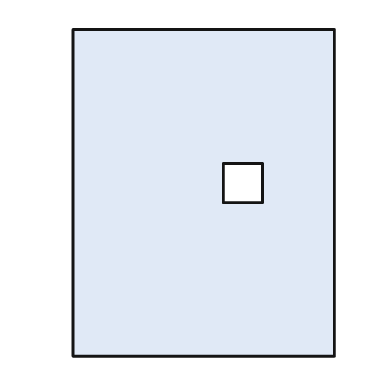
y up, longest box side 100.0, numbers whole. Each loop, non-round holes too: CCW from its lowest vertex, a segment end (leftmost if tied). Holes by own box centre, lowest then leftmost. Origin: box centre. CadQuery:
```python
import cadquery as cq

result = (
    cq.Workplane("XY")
    .moveTo(-40.0, -50.0)
    .lineTo(40.0, -50.0)
    .lineTo(40.0, 50.0)
    .lineTo(-40.0, 50.0)
    .close()
    .moveTo(6.0, -3.0)
    .lineTo(18.0, -3.0)
    .lineTo(18.0, 9.0)
    .lineTo(6.0, 9.0)
    .close()
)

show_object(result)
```